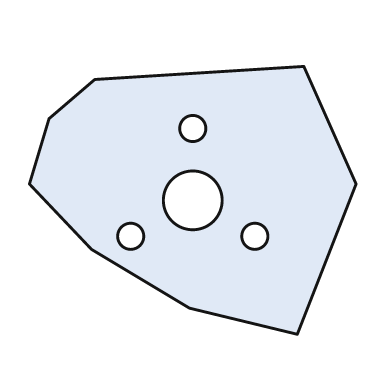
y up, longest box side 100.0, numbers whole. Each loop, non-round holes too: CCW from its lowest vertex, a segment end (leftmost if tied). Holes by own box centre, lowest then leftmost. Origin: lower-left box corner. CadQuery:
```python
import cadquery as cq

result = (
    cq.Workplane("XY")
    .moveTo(82.0, 0.0)
    .lineTo(100.0, 46.0)
    .lineTo(84.0, 82.0)
    .lineTo(20.0, 78.0)
    .lineTo(6.0, 66.0)
    .lineTo(0.0, 46.0)
    .lineTo(19.0, 26.0)
    .lineTo(49.0, 8.0)
    .close()
    .moveTo(31.0, 30.0)
    .circle(4.0)
    .moveTo(69.0, 30.0)
    .circle(4.0)
    .moveTo(50.0, 41.0)
    .circle(9.0)
    .moveTo(50.0, 63.0)
    .circle(4.0)
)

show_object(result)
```